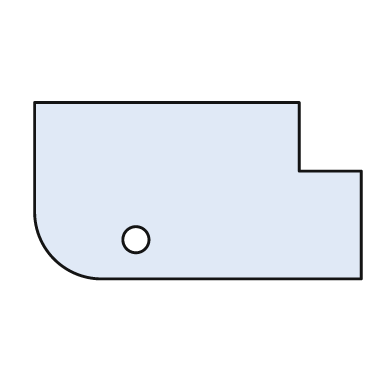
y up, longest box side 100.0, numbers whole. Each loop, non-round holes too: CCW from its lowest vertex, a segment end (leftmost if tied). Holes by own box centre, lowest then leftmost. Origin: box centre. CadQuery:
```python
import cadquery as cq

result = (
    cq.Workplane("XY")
    .moveTo(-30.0, -27.0)
    .lineTo(50.0, -27.0)
    .lineTo(50.0, 6.0)
    .lineTo(31.0, 6.0)
    .lineTo(31.0, 27.0)
    .lineTo(-50.0, 27.0)
    .lineTo(-50.0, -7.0)
    .threePointArc((-44.0, -21.0), (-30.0, -27.0))
    .close()
    .moveTo(-19.0, -15.0)
    .circle(4.0)
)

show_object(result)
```